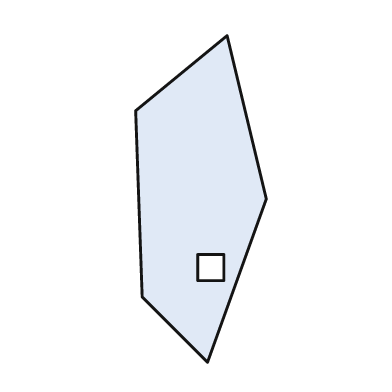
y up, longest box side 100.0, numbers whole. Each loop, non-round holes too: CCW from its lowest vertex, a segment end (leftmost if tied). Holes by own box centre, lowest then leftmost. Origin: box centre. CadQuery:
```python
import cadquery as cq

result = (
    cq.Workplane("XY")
    .moveTo(2.0, -50.0)
    .lineTo(20.0, 0.0)
    .lineTo(8.0, 50.0)
    .lineTo(-20.0, 27.0)
    .lineTo(-18.0, -30.0)
    .close()
    .moveTo(-1.0, -25.0)
    .lineTo(7.0, -25.0)
    .lineTo(7.0, -17.0)
    .lineTo(-1.0, -17.0)
    .close()
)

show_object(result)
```